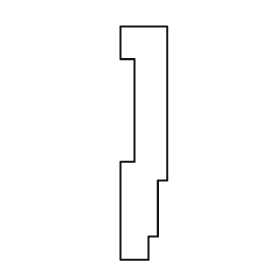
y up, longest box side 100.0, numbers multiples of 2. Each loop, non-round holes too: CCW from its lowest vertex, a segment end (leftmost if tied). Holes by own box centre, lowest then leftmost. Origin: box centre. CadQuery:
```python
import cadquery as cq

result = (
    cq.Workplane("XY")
    .moveTo(-10.0, -50.0)
    .lineTo(2.0, -50.0)
    .lineTo(2.0, -40.0)
    .lineTo(6.0, -40.0)
    .lineTo(6.0, -16.0)
    .lineTo(10.0, -16.0)
    .lineTo(10.0, 50.0)
    .lineTo(-10.0, 50.0)
    .lineTo(-10.0, 36.0)
    .lineTo(-4.0, 36.0)
    .lineTo(-4.0, -8.0)
    .lineTo(-10.0, -8.0)
    .close()
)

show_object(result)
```